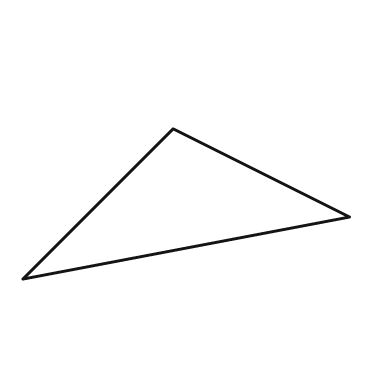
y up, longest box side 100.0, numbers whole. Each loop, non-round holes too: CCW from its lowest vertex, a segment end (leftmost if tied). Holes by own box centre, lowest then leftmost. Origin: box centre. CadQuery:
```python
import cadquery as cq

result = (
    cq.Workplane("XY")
    .moveTo(-50.0, -23.0)
    .lineTo(50.0, -4.0)
    .lineTo(-4.0, 23.0)
    .close()
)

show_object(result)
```